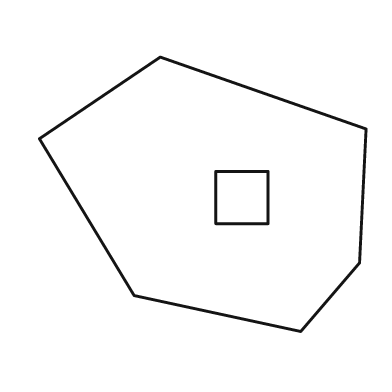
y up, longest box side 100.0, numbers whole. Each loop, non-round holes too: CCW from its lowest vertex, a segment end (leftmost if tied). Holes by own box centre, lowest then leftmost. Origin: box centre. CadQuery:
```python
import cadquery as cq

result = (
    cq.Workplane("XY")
    .moveTo(30.0, -42.0)
    .lineTo(48.0, -21.0)
    .lineTo(50.0, 20.0)
    .lineTo(-13.0, 42.0)
    .lineTo(-50.0, 17.0)
    .lineTo(-21.0, -31.0)
    .close()
    .moveTo(4.0, -9.0)
    .lineTo(20.0, -9.0)
    .lineTo(20.0, 7.0)
    .lineTo(4.0, 7.0)
    .close()
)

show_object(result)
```